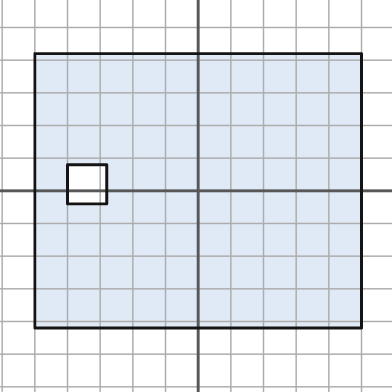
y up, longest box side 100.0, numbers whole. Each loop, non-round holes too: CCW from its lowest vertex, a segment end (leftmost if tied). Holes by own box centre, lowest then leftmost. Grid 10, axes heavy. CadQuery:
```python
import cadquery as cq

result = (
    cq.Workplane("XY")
    .moveTo(-50.0, -42.0)
    .lineTo(50.0, -42.0)
    .lineTo(50.0, 42.0)
    .lineTo(-50.0, 42.0)
    .close()
    .moveTo(-40.0, -4.0)
    .lineTo(-28.0, -4.0)
    .lineTo(-28.0, 8.0)
    .lineTo(-40.0, 8.0)
    .close()
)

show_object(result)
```